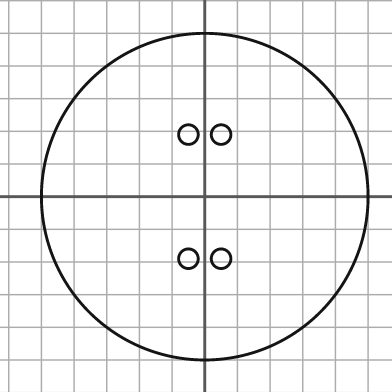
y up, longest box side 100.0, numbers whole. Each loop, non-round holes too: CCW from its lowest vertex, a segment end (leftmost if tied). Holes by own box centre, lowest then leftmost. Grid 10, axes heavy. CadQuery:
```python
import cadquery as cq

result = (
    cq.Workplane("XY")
    .moveTo(0.0, 0.0)
    .circle(50.0)
    .moveTo(-5.0, -19.0)
    .circle(3.0)
    .moveTo(5.0, -19.0)
    .circle(3.0)
    .moveTo(-5.0, 19.0)
    .circle(3.0)
    .moveTo(5.0, 19.0)
    .circle(3.0)
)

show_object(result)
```